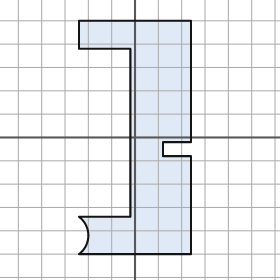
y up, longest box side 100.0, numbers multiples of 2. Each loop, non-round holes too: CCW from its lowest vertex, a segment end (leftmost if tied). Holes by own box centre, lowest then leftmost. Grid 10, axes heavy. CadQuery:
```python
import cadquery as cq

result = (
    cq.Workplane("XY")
    .moveTo(-24.0, -50.0)
    .lineTo(24.0, -50.0)
    .lineTo(24.0, -8.0)
    .lineTo(12.0, -8.0)
    .lineTo(12.0, -2.0)
    .lineTo(24.0, -2.0)
    .lineTo(24.0, 50.0)
    .lineTo(-24.0, 50.0)
    .lineTo(-24.0, 38.0)
    .lineTo(-2.0, 38.0)
    .lineTo(-2.0, -34.0)
    .lineTo(-24.0, -34.0)
    .threePointArc((-20.0, -42.0), (-24.0, -50.0))
    .close()
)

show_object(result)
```